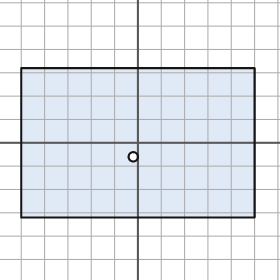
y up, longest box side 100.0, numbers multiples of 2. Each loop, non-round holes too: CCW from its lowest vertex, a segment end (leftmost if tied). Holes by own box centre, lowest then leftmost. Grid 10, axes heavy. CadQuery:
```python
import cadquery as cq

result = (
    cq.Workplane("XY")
    .moveTo(-50.0, -32.0)
    .lineTo(50.0, -32.0)
    .lineTo(50.0, 32.0)
    .lineTo(-50.0, 32.0)
    .close()
    .moveTo(-2.0, -6.0)
    .circle(2.0)
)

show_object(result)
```